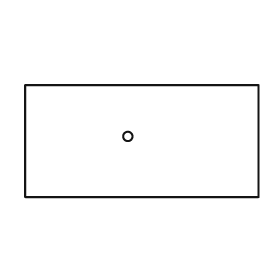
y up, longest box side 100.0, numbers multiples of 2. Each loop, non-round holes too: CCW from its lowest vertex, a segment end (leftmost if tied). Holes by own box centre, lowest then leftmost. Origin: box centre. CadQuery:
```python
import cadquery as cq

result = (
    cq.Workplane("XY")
    .moveTo(-50.0, -24.0)
    .lineTo(50.0, -24.0)
    .lineTo(50.0, 24.0)
    .lineTo(-50.0, 24.0)
    .close()
    .moveTo(-6.0, 2.0)
    .circle(2.0)
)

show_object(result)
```